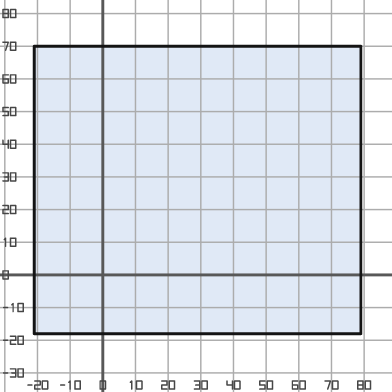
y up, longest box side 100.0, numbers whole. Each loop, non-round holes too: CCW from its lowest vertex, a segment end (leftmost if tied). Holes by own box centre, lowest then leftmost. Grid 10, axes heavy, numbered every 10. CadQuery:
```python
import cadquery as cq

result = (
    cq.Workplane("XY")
    .moveTo(-21.0, -18.0)
    .lineTo(79.0, -18.0)
    .lineTo(79.0, 70.0)
    .lineTo(-21.0, 70.0)
    .close()
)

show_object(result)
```